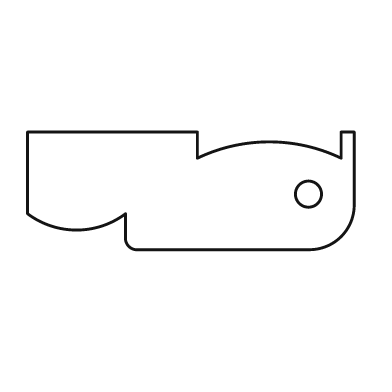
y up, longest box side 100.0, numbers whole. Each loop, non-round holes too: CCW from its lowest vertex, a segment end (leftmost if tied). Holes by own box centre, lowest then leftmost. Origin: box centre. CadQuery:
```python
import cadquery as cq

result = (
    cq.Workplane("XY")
    .moveTo(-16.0, -18.0)
    .lineTo(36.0, -18.0)
    .threePointArc((46.0, -14.0), (50.0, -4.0))
    .lineTo(50.0, 18.0)
    .lineTo(46.0, 18.0)
    .lineTo(46.0, 10.0)
    .threePointArc((24.0, 15.0), (2.0, 10.0))
    .lineTo(2.0, 18.0)
    .lineTo(-50.0, 18.0)
    .lineTo(-50.0, -7.0)
    .threePointArc((-35.0, -12.0), (-20.0, -7.0))
    .lineTo(-20.0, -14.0)
    .threePointArc((-19.0, -17.0), (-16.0, -18.0))
    .close()
    .moveTo(36.0, -1.0)
    .circle(4.0)
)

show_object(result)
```